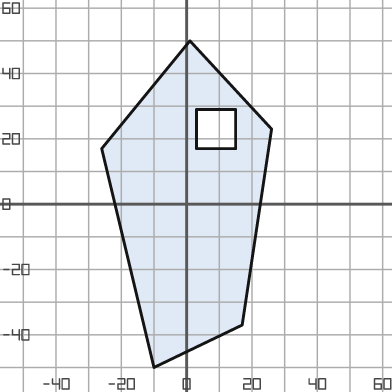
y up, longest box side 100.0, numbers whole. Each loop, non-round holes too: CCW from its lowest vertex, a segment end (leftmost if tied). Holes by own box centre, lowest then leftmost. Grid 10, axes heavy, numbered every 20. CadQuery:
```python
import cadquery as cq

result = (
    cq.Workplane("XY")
    .moveTo(-10.0, -50.0)
    .lineTo(17.0, -37.0)
    .lineTo(26.0, 23.0)
    .lineTo(1.0, 50.0)
    .lineTo(-26.0, 17.0)
    .close()
    .moveTo(3.0, 17.0)
    .lineTo(15.0, 17.0)
    .lineTo(15.0, 29.0)
    .lineTo(3.0, 29.0)
    .close()
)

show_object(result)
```